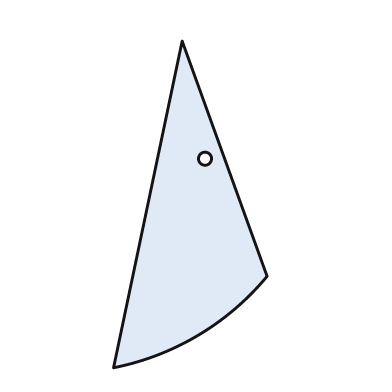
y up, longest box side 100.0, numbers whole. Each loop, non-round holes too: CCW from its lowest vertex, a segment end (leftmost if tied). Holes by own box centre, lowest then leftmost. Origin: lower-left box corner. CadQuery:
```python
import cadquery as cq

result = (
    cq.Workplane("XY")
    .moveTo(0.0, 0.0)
    .threePointArc((26.0, 10.0), (47.0, 28.0))
    .lineTo(21.0, 100.0)
    .close()
    .moveTo(28.0, 64.0)
    .circle(2.0)
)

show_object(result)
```